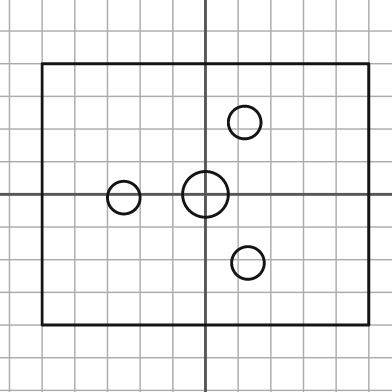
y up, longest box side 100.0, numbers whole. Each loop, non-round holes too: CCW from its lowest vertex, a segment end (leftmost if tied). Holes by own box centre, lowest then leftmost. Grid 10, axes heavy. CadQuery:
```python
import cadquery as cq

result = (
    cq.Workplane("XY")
    .moveTo(-50.0, -40.0)
    .lineTo(50.0, -40.0)
    .lineTo(50.0, 40.0)
    .lineTo(-50.0, 40.0)
    .close()
    .moveTo(13.0, -21.0)
    .circle(5.0)
    .moveTo(-25.0, -1.0)
    .circle(5.0)
    .moveTo(0.0, 0.0)
    .circle(7.0)
    .moveTo(12.0, 22.0)
    .circle(5.0)
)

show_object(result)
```